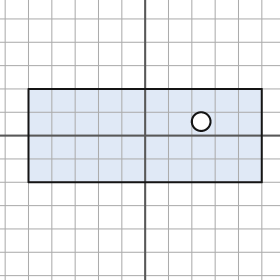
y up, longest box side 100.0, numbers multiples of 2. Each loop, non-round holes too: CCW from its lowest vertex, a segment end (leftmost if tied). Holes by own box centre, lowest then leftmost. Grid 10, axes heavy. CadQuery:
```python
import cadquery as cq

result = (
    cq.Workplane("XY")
    .moveTo(-50.0, -20.0)
    .lineTo(50.0, -20.0)
    .lineTo(50.0, 20.0)
    .lineTo(-50.0, 20.0)
    .close()
    .moveTo(24.0, 6.0)
    .circle(4.0)
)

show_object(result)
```